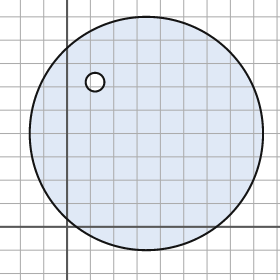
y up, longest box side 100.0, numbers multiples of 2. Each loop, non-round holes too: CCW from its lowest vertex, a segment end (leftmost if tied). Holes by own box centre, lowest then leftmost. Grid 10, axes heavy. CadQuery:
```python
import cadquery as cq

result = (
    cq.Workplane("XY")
    .moveTo(34.0, 40.0)
    .circle(50.0)
    .moveTo(12.0, 62.0)
    .circle(4.0)
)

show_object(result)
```